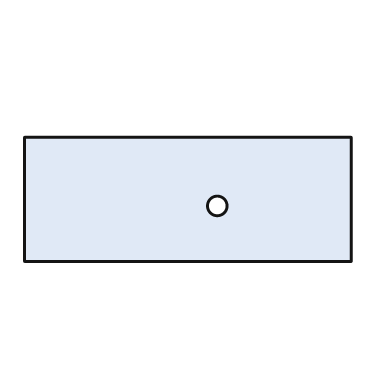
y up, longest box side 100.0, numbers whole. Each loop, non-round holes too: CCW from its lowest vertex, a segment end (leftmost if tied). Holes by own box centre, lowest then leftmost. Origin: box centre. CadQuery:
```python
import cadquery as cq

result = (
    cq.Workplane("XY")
    .moveTo(-50.0, -19.0)
    .lineTo(50.0, -19.0)
    .lineTo(50.0, 19.0)
    .lineTo(-50.0, 19.0)
    .close()
    .moveTo(9.0, -2.0)
    .circle(3.0)
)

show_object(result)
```